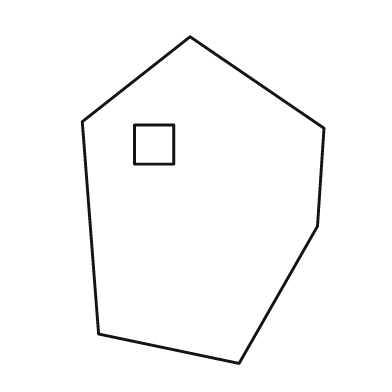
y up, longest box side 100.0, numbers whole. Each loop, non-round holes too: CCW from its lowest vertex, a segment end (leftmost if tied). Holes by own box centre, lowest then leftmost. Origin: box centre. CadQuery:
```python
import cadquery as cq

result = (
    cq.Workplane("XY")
    .moveTo(11.0, -50.0)
    .lineTo(35.0, -8.0)
    .lineTo(37.0, 22.0)
    .lineTo(-4.0, 50.0)
    .lineTo(-37.0, 24.0)
    .lineTo(-32.0, -41.0)
    .close()
    .moveTo(-21.0, 11.0)
    .lineTo(-9.0, 11.0)
    .lineTo(-9.0, 23.0)
    .lineTo(-21.0, 23.0)
    .close()
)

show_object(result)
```